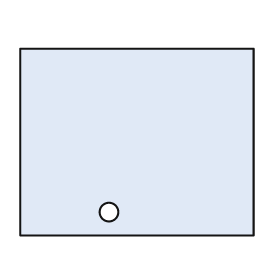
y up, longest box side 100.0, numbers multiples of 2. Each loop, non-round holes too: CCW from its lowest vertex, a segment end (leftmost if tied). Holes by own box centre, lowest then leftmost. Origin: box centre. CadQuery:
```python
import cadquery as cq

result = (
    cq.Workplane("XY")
    .moveTo(-50.0, -40.0)
    .lineTo(50.0, -40.0)
    .lineTo(50.0, 40.0)
    .lineTo(-50.0, 40.0)
    .close()
    .moveTo(-12.0, -30.0)
    .circle(4.0)
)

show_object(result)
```